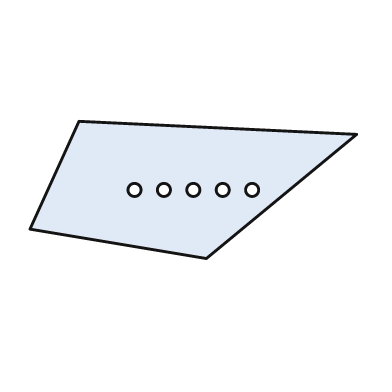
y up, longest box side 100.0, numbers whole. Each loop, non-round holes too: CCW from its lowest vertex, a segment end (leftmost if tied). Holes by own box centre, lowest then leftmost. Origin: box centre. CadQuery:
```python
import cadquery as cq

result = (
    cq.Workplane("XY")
    .moveTo(4.0, -21.0)
    .lineTo(50.0, 17.0)
    .lineTo(-35.0, 21.0)
    .lineTo(-50.0, -12.0)
    .close()
    .moveTo(-18.0, 0.0)
    .circle(2.0)
    .moveTo(-9.0, 0.0)
    .circle(2.0)
    .moveTo(0.0, 0.0)
    .circle(2.0)
    .moveTo(9.0, 0.0)
    .circle(2.0)
    .moveTo(18.0, 0.0)
    .circle(2.0)
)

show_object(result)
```